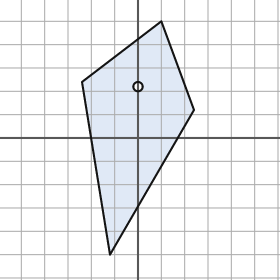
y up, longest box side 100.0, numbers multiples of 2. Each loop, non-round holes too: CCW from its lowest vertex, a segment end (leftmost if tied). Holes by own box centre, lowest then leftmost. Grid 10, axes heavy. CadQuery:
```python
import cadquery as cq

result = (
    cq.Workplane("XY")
    .moveTo(-12.0, -50.0)
    .lineTo(24.0, 12.0)
    .lineTo(10.0, 50.0)
    .lineTo(-24.0, 24.0)
    .close()
    .moveTo(0.0, 22.0)
    .circle(2.0)
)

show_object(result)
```